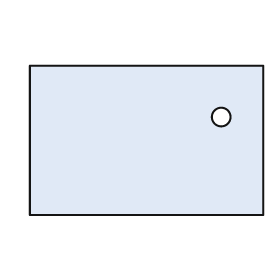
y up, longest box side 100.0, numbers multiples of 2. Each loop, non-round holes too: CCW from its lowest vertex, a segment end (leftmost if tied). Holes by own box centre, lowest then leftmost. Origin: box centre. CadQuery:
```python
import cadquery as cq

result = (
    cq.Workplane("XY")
    .moveTo(-50.0, -32.0)
    .lineTo(50.0, -32.0)
    .lineTo(50.0, 32.0)
    .lineTo(-50.0, 32.0)
    .close()
    .moveTo(32.0, 10.0)
    .circle(4.0)
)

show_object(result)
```